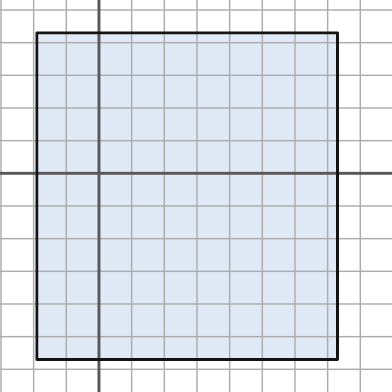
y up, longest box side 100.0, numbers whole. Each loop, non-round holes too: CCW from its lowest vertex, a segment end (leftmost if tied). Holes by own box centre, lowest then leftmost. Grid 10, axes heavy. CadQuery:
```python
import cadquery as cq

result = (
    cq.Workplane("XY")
    .moveTo(-19.0, -57.0)
    .lineTo(73.0, -57.0)
    .lineTo(73.0, 43.0)
    .lineTo(-19.0, 43.0)
    .close()
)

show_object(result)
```